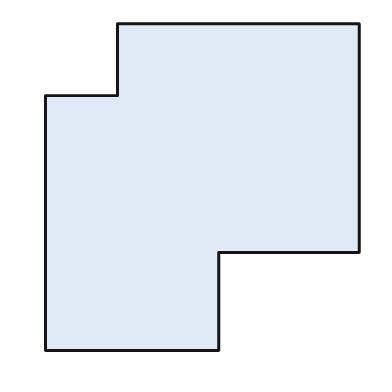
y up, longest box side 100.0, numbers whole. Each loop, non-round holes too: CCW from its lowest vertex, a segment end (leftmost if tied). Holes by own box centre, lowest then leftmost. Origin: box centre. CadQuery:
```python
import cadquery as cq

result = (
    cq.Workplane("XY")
    .moveTo(-48.0, -50.0)
    .lineTo(5.0, -50.0)
    .lineTo(5.0, -20.0)
    .lineTo(48.0, -20.0)
    .lineTo(48.0, 50.0)
    .lineTo(-26.0, 50.0)
    .lineTo(-26.0, 28.0)
    .lineTo(-48.0, 28.0)
    .close()
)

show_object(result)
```